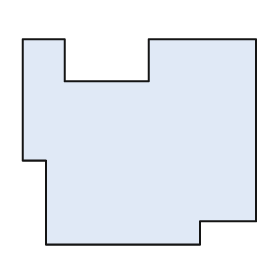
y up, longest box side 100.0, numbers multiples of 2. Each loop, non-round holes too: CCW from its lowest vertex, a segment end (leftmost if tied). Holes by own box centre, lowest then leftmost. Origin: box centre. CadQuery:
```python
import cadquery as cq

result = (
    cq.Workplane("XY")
    .moveTo(-40.0, -44.0)
    .lineTo(26.0, -44.0)
    .lineTo(26.0, -34.0)
    .lineTo(50.0, -34.0)
    .lineTo(50.0, 44.0)
    .lineTo(4.0, 44.0)
    .lineTo(4.0, 26.0)
    .lineTo(-32.0, 26.0)
    .lineTo(-32.0, 44.0)
    .lineTo(-50.0, 44.0)
    .lineTo(-50.0, -8.0)
    .lineTo(-40.0, -8.0)
    .close()
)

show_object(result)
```